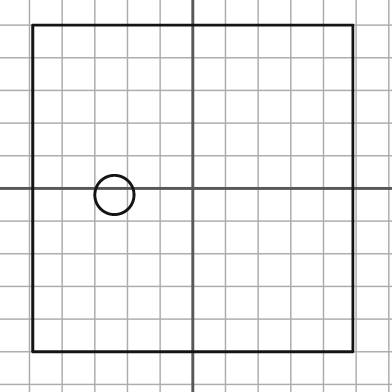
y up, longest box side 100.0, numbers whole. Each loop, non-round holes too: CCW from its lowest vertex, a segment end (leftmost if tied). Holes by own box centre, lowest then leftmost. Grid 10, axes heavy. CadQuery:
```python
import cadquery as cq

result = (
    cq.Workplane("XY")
    .moveTo(-49.0, -50.0)
    .lineTo(49.0, -50.0)
    .lineTo(49.0, 50.0)
    .lineTo(-49.0, 50.0)
    .close()
    .moveTo(-24.0, -2.0)
    .circle(6.0)
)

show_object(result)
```